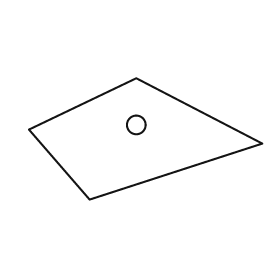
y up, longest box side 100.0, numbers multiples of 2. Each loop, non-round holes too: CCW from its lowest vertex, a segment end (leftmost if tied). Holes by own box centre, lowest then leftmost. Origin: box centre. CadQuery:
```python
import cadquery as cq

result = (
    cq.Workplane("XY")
    .moveTo(-24.0, -26.0)
    .lineTo(50.0, -2.0)
    .lineTo(-4.0, 26.0)
    .lineTo(-50.0, 4.0)
    .close()
    .moveTo(-4.0, 6.0)
    .circle(4.0)
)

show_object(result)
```